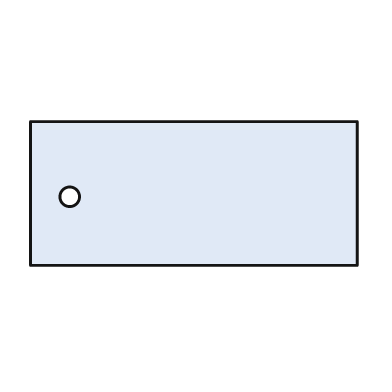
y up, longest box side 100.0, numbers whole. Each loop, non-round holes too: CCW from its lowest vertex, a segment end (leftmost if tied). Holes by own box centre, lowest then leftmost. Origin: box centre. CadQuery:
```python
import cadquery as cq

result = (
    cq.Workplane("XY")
    .moveTo(-50.0, -22.0)
    .lineTo(50.0, -22.0)
    .lineTo(50.0, 22.0)
    .lineTo(-50.0, 22.0)
    .close()
    .moveTo(-38.0, -1.0)
    .circle(3.0)
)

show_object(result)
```